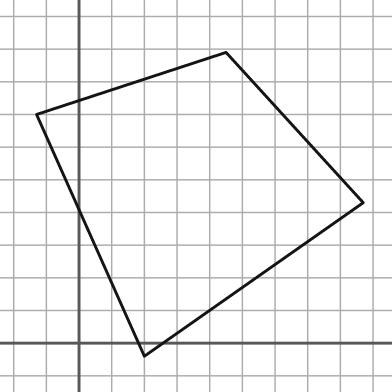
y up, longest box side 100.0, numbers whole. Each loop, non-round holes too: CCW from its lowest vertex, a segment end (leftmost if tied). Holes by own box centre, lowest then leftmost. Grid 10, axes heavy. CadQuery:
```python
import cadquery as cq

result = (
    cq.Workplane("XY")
    .moveTo(20.0, -4.0)
    .lineTo(87.0, 43.0)
    .lineTo(45.0, 89.0)
    .lineTo(-13.0, 70.0)
    .close()
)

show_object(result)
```